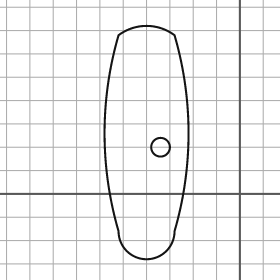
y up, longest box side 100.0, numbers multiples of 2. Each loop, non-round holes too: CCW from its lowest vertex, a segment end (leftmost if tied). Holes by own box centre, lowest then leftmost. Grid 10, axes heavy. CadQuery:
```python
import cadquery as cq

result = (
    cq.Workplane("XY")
    .moveTo(-52.0, -16.0)
    .threePointArc((-40.0, -28.0), (-28.0, -16.0))
    .threePointArc((-22.0, 26.0), (-28.0, 68.0))
    .threePointArc((-40.0, 72.0), (-52.0, 68.0))
    .threePointArc((-58.0, 26.0), (-52.0, -16.0))
    .close()
    .moveTo(-34.0, 20.0)
    .circle(4.0)
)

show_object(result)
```